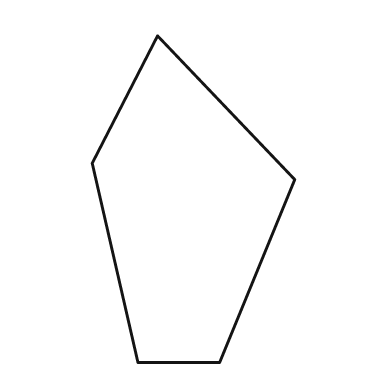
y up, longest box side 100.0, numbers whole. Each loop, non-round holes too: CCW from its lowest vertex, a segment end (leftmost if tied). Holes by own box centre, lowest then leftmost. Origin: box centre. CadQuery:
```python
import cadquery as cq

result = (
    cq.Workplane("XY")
    .moveTo(-17.0, -50.0)
    .lineTo(8.0, -50.0)
    .lineTo(31.0, 6.0)
    .lineTo(-11.0, 50.0)
    .lineTo(-31.0, 11.0)
    .close()
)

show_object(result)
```